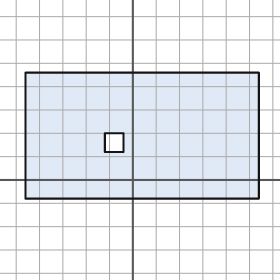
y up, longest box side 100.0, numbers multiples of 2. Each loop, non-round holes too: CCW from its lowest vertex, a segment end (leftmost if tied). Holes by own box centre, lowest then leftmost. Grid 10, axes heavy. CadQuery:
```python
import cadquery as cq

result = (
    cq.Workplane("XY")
    .moveTo(-46.0, -8.0)
    .lineTo(54.0, -8.0)
    .lineTo(54.0, 46.0)
    .lineTo(-46.0, 46.0)
    .close()
    .moveTo(-12.0, 12.0)
    .lineTo(-4.0, 12.0)
    .lineTo(-4.0, 20.0)
    .lineTo(-12.0, 20.0)
    .close()
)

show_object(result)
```